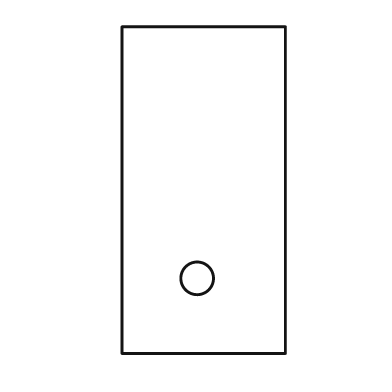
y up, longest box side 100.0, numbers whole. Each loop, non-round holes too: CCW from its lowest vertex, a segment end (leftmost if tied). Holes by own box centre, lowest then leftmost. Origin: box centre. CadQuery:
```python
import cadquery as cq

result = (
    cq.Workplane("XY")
    .moveTo(-25.0, -50.0)
    .lineTo(25.0, -50.0)
    .lineTo(25.0, 50.0)
    .lineTo(-25.0, 50.0)
    .close()
    .moveTo(-2.0, -27.0)
    .circle(5.0)
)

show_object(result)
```